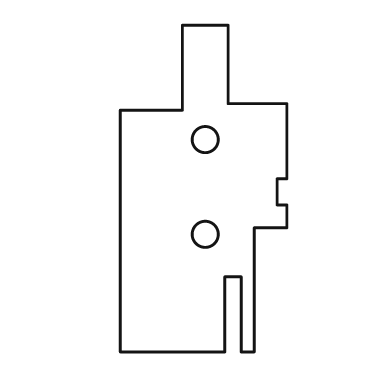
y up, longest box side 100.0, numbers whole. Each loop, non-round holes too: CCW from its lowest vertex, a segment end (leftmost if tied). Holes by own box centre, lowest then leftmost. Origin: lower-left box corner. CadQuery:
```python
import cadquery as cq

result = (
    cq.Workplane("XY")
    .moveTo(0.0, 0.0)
    .lineTo(32.0, 0.0)
    .lineTo(32.0, 23.0)
    .lineTo(37.0, 23.0)
    .lineTo(37.0, 0.0)
    .lineTo(41.0, 0.0)
    .lineTo(41.0, 38.0)
    .lineTo(51.0, 38.0)
    .lineTo(51.0, 45.0)
    .lineTo(48.0, 45.0)
    .lineTo(48.0, 53.0)
    .lineTo(51.0, 53.0)
    .lineTo(51.0, 76.0)
    .lineTo(33.0, 76.0)
    .lineTo(33.0, 100.0)
    .lineTo(19.0, 100.0)
    .lineTo(19.0, 74.0)
    .lineTo(0.0, 74.0)
    .close()
    .moveTo(26.0, 36.0)
    .circle(4.0)
    .moveTo(26.0, 65.0)
    .circle(4.0)
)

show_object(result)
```